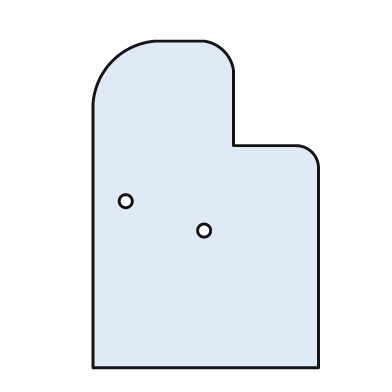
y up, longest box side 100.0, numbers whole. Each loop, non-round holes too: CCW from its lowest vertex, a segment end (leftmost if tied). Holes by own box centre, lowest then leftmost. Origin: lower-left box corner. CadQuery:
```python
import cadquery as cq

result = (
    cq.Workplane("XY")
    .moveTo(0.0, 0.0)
    .lineTo(69.0, 0.0)
    .lineTo(69.0, 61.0)
    .threePointArc((67.0, 66.0), (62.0, 68.0))
    .lineTo(43.0, 68.0)
    .lineTo(43.0, 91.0)
    .threePointArc((40.0, 97.0), (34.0, 100.0))
    .lineTo(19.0, 100.0)
    .threePointArc((6.0, 94.0), (0.0, 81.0))
    .close()
    .moveTo(34.0, 42.0)
    .circle(2.0)
    .moveTo(10.0, 51.0)
    .circle(2.0)
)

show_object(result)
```